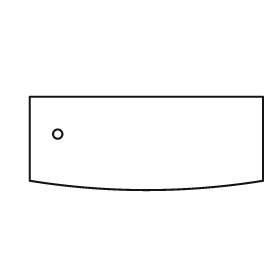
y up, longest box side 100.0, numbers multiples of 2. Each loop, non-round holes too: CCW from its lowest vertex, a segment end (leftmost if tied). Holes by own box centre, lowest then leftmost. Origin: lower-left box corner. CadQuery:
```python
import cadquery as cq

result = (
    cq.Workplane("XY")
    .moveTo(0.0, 4.0)
    .threePointArc((50.0, 0.0), (100.0, 4.0))
    .lineTo(100.0, 40.0)
    .lineTo(0.0, 40.0)
    .close()
    .moveTo(12.0, 24.0)
    .circle(2.0)
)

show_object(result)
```